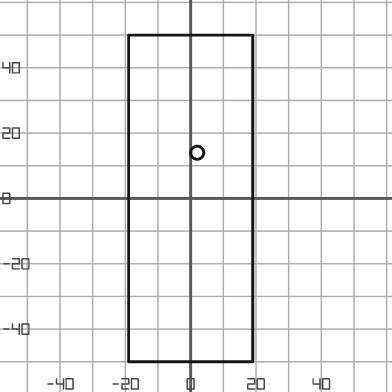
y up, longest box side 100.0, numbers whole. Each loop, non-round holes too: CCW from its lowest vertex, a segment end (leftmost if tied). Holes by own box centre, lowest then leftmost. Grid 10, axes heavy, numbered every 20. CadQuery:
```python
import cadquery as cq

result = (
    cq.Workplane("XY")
    .moveTo(-19.0, -50.0)
    .lineTo(19.0, -50.0)
    .lineTo(19.0, 50.0)
    .lineTo(-19.0, 50.0)
    .close()
    .moveTo(2.0, 14.0)
    .circle(2.0)
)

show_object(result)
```